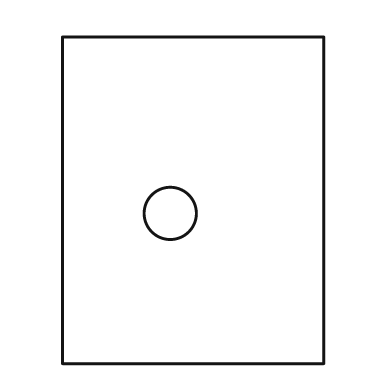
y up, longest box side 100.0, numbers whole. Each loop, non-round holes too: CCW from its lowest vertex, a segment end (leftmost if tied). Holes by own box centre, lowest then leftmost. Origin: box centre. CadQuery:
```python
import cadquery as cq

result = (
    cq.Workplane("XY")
    .moveTo(-40.0, -50.0)
    .lineTo(40.0, -50.0)
    .lineTo(40.0, 50.0)
    .lineTo(-40.0, 50.0)
    .close()
    .moveTo(-7.0, -4.0)
    .circle(8.0)
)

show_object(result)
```